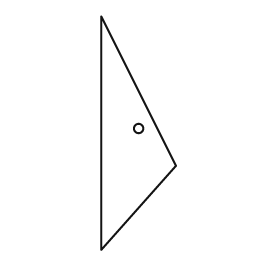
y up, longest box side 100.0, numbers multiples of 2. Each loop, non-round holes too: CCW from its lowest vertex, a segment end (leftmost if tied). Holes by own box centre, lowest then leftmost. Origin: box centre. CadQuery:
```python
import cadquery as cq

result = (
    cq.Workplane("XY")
    .moveTo(-16.0, -50.0)
    .lineTo(16.0, -14.0)
    .lineTo(-16.0, 50.0)
    .close()
    .moveTo(0.0, 2.0)
    .circle(2.0)
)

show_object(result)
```